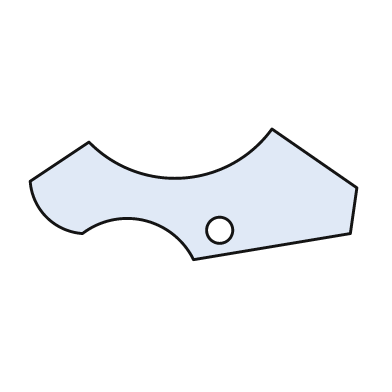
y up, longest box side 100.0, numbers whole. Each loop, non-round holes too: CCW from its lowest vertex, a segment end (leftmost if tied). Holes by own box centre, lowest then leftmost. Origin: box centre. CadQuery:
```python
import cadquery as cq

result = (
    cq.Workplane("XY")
    .moveTo(0.0, -20.0)
    .lineTo(48.0, -12.0)
    .lineTo(50.0, 2.0)
    .lineTo(24.0, 20.0)
    .threePointArc((-3.0, 5.0), (-32.0, 16.0))
    .lineTo(-50.0, 4.0)
    .threePointArc((-45.0, -7.0), (-34.0, -12.0))
    .threePointArc((-15.0, -8.0), (0.0, -20.0))
    .close()
    .moveTo(8.0, -11.0)
    .circle(4.0)
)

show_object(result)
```